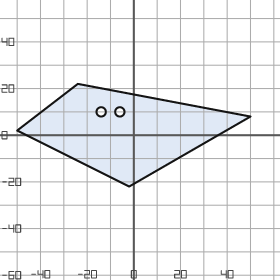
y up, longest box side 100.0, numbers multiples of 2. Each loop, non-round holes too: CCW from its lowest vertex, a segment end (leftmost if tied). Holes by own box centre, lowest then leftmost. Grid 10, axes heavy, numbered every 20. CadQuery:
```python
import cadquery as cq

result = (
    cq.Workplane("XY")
    .moveTo(-2.0, -22.0)
    .lineTo(50.0, 8.0)
    .lineTo(-24.0, 22.0)
    .lineTo(-50.0, 2.0)
    .close()
    .moveTo(-14.0, 10.0)
    .circle(2.0)
    .moveTo(-6.0, 10.0)
    .circle(2.0)
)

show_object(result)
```